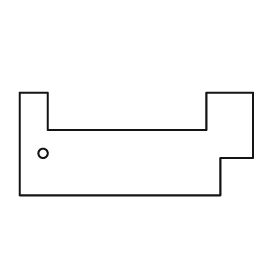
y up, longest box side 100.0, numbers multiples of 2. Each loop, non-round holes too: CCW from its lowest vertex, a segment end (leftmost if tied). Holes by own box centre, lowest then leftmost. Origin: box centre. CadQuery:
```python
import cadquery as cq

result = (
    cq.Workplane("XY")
    .moveTo(-50.0, -22.0)
    .lineTo(36.0, -22.0)
    .lineTo(36.0, -6.0)
    .lineTo(50.0, -6.0)
    .lineTo(50.0, 22.0)
    .lineTo(30.0, 22.0)
    .lineTo(30.0, 6.0)
    .lineTo(-38.0, 6.0)
    .lineTo(-38.0, 22.0)
    .lineTo(-50.0, 22.0)
    .close()
    .moveTo(-40.0, -4.0)
    .circle(2.0)
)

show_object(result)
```